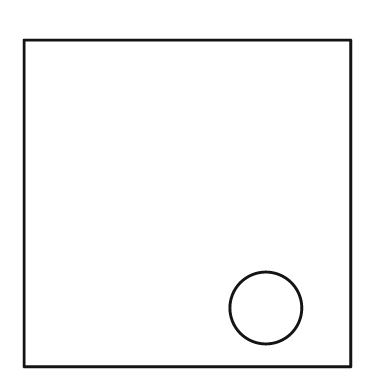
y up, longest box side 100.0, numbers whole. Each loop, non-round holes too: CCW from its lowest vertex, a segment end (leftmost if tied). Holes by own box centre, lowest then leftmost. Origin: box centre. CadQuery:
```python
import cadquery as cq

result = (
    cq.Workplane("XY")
    .moveTo(-50.0, -50.0)
    .lineTo(50.0, -50.0)
    .lineTo(50.0, 50.0)
    .lineTo(-50.0, 50.0)
    .close()
    .moveTo(24.0, -32.0)
    .circle(11.0)
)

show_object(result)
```